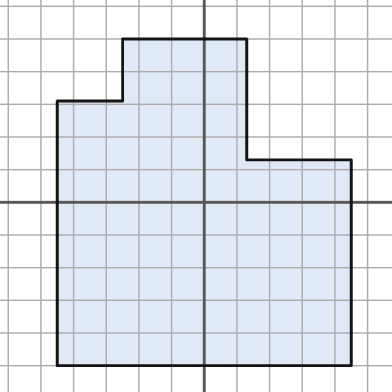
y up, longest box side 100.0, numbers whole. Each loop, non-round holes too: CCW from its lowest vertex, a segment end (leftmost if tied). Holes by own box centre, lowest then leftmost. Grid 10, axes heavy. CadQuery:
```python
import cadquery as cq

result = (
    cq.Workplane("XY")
    .moveTo(-45.0, -50.0)
    .lineTo(45.0, -50.0)
    .lineTo(45.0, 13.0)
    .lineTo(13.0, 13.0)
    .lineTo(13.0, 50.0)
    .lineTo(-25.0, 50.0)
    .lineTo(-25.0, 31.0)
    .lineTo(-45.0, 31.0)
    .close()
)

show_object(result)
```